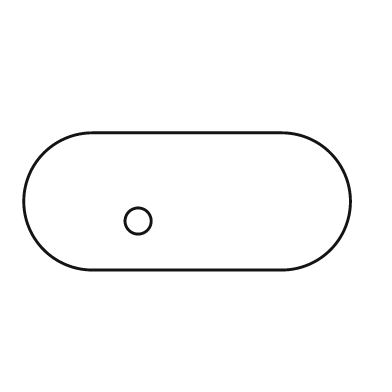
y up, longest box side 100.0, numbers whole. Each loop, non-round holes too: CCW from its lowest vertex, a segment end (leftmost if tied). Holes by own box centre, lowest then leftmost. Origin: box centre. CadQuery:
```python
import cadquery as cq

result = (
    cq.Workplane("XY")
    .moveTo(-29.0, -21.0)
    .lineTo(29.0, -21.0)
    .threePointArc((50.0, 0.0), (29.0, 21.0))
    .lineTo(-29.0, 21.0)
    .threePointArc((-50.0, 0.0), (-29.0, -21.0))
    .close()
    .moveTo(-15.0, -6.0)
    .circle(4.0)
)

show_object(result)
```